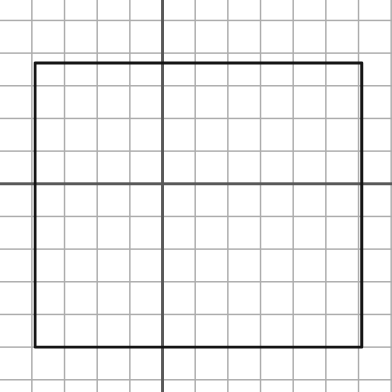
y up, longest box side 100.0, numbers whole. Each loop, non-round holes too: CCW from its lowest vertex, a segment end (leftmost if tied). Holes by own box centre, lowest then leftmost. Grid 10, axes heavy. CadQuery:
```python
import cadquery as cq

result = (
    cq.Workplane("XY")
    .moveTo(-39.0, -50.0)
    .lineTo(61.0, -50.0)
    .lineTo(61.0, 37.0)
    .lineTo(-39.0, 37.0)
    .close()
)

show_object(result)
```